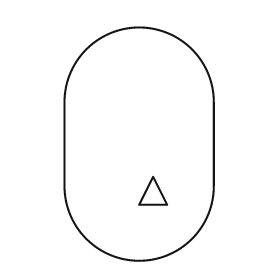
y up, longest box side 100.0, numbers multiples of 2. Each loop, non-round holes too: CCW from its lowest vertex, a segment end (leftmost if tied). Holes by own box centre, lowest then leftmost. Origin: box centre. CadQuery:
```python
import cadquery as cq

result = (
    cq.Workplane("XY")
    .moveTo(-32.0, -18.0)
    .threePointArc((0.0, -50.0), (32.0, -18.0))
    .lineTo(32.0, 18.0)
    .threePointArc((0.0, 50.0), (-32.0, 18.0))
    .close()
    .moveTo(0.0, -26.0)
    .lineTo(12.0, -26.0)
    .lineTo(6.0, -14.0)
    .close()
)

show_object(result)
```